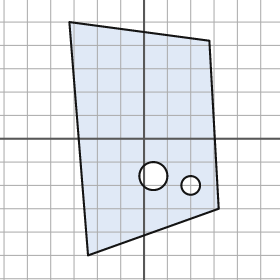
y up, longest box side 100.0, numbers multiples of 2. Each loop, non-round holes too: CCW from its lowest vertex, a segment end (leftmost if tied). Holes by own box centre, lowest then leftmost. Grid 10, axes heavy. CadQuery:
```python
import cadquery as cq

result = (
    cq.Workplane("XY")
    .moveTo(-24.0, -50.0)
    .lineTo(32.0, -30.0)
    .lineTo(28.0, 42.0)
    .lineTo(-32.0, 50.0)
    .close()
    .moveTo(20.0, -20.0)
    .circle(4.0)
    .moveTo(4.0, -16.0)
    .circle(6.0)
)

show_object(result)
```